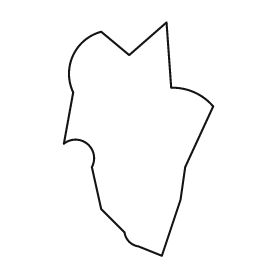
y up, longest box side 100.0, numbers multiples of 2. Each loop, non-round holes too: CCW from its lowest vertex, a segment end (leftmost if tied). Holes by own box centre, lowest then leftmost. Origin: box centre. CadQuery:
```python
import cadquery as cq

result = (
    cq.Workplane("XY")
    .moveTo(10.0, -50.0)
    .lineTo(18.0, -26.0)
    .lineTo(20.0, -12.0)
    .lineTo(32.0, 14.0)
    .threePointArc((24.0, 20.0), (14.0, 22.0))
    .lineTo(12.0, 50.0)
    .lineTo(-4.0, 36.0)
    .lineTo(-16.0, 46.0)
    .threePointArc((-28.0, 36.0), (-28.0, 20.0))
    .lineTo(-32.0, -2.0)
    .threePointArc((-22.0, -2.0), (-20.0, -12.0))
    .lineTo(-16.0, -30.0)
    .lineTo(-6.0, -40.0)
    .threePointArc((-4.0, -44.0), (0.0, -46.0))
    .close()
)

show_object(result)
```